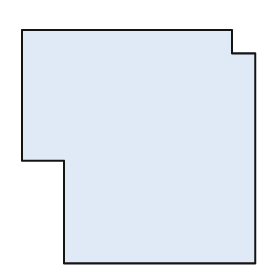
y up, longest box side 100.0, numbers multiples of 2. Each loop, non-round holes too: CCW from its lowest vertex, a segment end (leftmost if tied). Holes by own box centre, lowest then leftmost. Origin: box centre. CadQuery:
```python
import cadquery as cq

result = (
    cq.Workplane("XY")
    .moveTo(-32.0, -50.0)
    .lineTo(50.0, -50.0)
    .lineTo(50.0, 40.0)
    .lineTo(40.0, 40.0)
    .lineTo(40.0, 50.0)
    .lineTo(-50.0, 50.0)
    .lineTo(-50.0, -6.0)
    .lineTo(-32.0, -6.0)
    .close()
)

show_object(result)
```